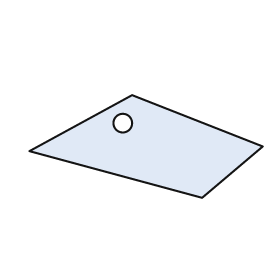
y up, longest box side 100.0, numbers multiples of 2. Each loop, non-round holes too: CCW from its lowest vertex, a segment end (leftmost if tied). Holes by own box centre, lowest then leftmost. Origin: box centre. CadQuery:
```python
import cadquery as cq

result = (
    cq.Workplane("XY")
    .moveTo(24.0, -22.0)
    .lineTo(50.0, 0.0)
    .lineTo(-6.0, 22.0)
    .lineTo(-50.0, -2.0)
    .close()
    .moveTo(-10.0, 10.0)
    .circle(4.0)
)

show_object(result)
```